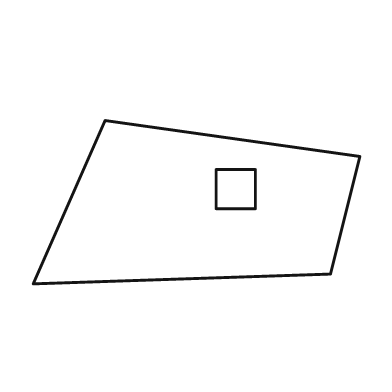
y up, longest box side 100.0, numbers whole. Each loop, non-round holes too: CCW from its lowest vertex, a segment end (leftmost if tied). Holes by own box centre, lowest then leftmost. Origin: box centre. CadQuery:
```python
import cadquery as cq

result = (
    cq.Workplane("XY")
    .moveTo(-50.0, -25.0)
    .lineTo(41.0, -22.0)
    .lineTo(50.0, 14.0)
    .lineTo(-28.0, 25.0)
    .close()
    .moveTo(6.0, -2.0)
    .lineTo(18.0, -2.0)
    .lineTo(18.0, 10.0)
    .lineTo(6.0, 10.0)
    .close()
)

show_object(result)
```